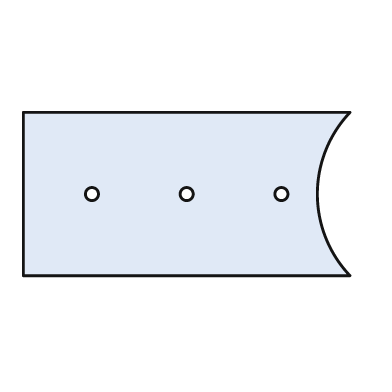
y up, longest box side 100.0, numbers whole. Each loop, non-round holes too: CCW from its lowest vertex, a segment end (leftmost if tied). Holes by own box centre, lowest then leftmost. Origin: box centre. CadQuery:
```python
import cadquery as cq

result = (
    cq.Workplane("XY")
    .moveTo(-50.0, -25.0)
    .lineTo(50.0, -25.0)
    .threePointArc((40.0, 0.0), (50.0, 25.0))
    .lineTo(-50.0, 25.0)
    .close()
    .moveTo(-29.0, 0.0)
    .circle(2.0)
    .moveTo(0.0, 0.0)
    .circle(2.0)
    .moveTo(29.0, 0.0)
    .circle(2.0)
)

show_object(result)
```